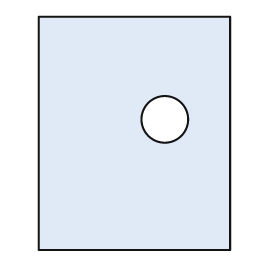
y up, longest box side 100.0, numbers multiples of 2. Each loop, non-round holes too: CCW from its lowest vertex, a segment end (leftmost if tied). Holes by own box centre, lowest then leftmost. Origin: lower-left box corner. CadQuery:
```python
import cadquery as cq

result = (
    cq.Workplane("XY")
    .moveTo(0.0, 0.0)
    .lineTo(82.0, 0.0)
    .lineTo(82.0, 100.0)
    .lineTo(0.0, 100.0)
    .close()
    .moveTo(54.0, 56.0)
    .circle(10.0)
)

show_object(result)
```